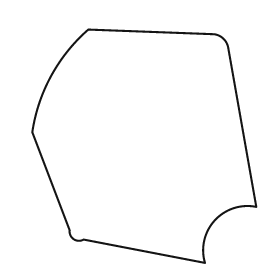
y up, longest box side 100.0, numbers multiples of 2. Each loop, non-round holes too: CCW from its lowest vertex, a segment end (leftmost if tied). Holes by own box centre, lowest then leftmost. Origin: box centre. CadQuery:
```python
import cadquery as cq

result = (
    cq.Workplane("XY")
    .moveTo(26.0, -50.0)
    .threePointArc((30.0, -32.0), (48.0, -26.0))
    .lineTo(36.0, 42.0)
    .threePointArc((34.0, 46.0), (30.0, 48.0))
    .lineTo(-24.0, 50.0)
    .threePointArc((-40.0, 30.0), (-48.0, 6.0))
    .lineTo(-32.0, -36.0)
    .threePointArc((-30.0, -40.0), (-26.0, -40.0))
    .close()
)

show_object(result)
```